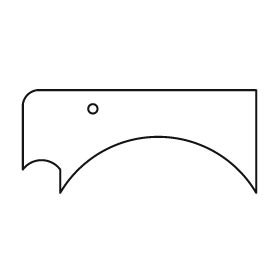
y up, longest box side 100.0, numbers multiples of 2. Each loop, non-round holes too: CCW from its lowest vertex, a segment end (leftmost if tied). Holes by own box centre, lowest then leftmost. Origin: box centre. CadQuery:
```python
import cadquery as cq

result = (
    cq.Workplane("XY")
    .moveTo(-34.0, -22.0)
    .threePointArc((8.0, 2.0), (50.0, -22.0))
    .lineTo(50.0, 22.0)
    .lineTo(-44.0, 22.0)
    .threePointArc((-48.0, 20.0), (-50.0, 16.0))
    .lineTo(-50.0, -12.0)
    .threePointArc((-42.0, -8.0), (-34.0, -12.0))
    .close()
    .moveTo(-20.0, 14.0)
    .circle(2.0)
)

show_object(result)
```